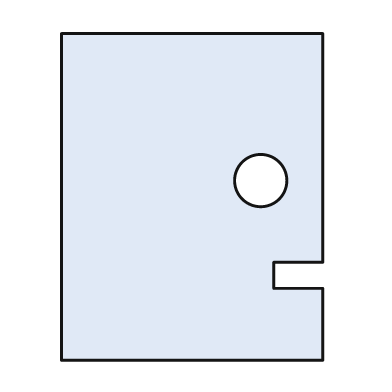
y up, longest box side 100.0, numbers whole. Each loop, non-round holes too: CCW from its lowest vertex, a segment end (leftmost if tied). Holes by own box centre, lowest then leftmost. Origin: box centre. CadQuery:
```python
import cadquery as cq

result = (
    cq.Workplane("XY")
    .moveTo(-40.0, -50.0)
    .lineTo(40.0, -50.0)
    .lineTo(40.0, -28.0)
    .lineTo(25.0, -28.0)
    .lineTo(25.0, -20.0)
    .lineTo(40.0, -20.0)
    .lineTo(40.0, 50.0)
    .lineTo(-40.0, 50.0)
    .close()
    .moveTo(21.0, 5.0)
    .circle(8.0)
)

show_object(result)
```